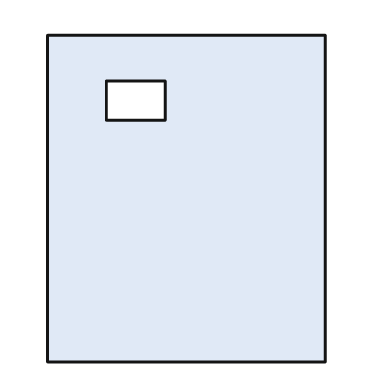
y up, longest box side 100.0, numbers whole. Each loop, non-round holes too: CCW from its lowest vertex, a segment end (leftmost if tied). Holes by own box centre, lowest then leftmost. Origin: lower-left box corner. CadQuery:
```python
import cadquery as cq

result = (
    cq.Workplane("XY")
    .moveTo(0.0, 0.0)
    .lineTo(85.0, 0.0)
    .lineTo(85.0, 100.0)
    .lineTo(0.0, 100.0)
    .close()
    .moveTo(18.0, 74.0)
    .lineTo(36.0, 74.0)
    .lineTo(36.0, 86.0)
    .lineTo(18.0, 86.0)
    .close()
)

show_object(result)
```